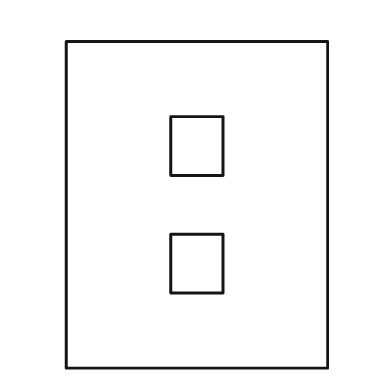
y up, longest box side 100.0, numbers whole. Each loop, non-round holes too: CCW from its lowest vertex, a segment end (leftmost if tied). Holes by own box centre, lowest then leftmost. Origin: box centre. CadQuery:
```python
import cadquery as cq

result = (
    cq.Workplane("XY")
    .moveTo(-40.0, -50.0)
    .lineTo(40.0, -50.0)
    .lineTo(40.0, 50.0)
    .lineTo(-40.0, 50.0)
    .close()
    .moveTo(-8.0, -27.0)
    .lineTo(8.0, -27.0)
    .lineTo(8.0, -9.0)
    .lineTo(-8.0, -9.0)
    .close()
    .moveTo(-8.0, 9.0)
    .lineTo(8.0, 9.0)
    .lineTo(8.0, 27.0)
    .lineTo(-8.0, 27.0)
    .close()
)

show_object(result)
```